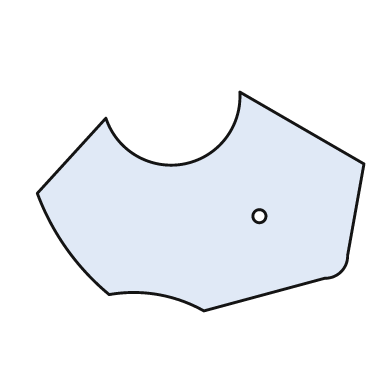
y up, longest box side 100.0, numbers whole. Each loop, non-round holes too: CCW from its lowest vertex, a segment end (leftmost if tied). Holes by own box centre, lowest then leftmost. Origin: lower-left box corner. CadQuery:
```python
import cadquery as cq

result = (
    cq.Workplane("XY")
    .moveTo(51.0, 0.0)
    .lineTo(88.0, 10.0)
    .threePointArc((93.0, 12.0), (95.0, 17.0))
    .lineTo(100.0, 45.0)
    .lineTo(62.0, 67.0)
    .threePointArc((45.0, 45.0), (21.0, 59.0))
    .lineTo(0.0, 36.0)
    .threePointArc((9.0, 19.0), (22.0, 5.0))
    .threePointArc((37.0, 5.0), (51.0, 0.0))
    .close()
    .moveTo(68.0, 29.0)
    .circle(2.0)
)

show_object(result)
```